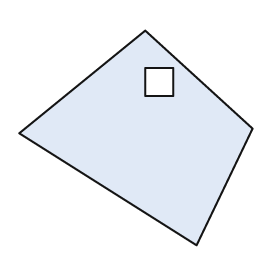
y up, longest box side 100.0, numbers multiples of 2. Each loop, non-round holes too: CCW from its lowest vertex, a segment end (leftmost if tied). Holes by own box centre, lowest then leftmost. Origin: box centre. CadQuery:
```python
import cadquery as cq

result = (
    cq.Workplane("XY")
    .moveTo(26.0, -46.0)
    .lineTo(50.0, 4.0)
    .lineTo(4.0, 46.0)
    .lineTo(-50.0, 2.0)
    .close()
    .moveTo(4.0, 18.0)
    .lineTo(16.0, 18.0)
    .lineTo(16.0, 30.0)
    .lineTo(4.0, 30.0)
    .close()
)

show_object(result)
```